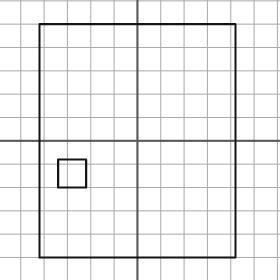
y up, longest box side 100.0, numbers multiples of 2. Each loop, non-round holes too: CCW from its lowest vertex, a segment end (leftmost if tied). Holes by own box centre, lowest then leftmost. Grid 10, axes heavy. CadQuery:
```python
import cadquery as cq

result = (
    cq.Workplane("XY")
    .moveTo(-42.0, -50.0)
    .lineTo(42.0, -50.0)
    .lineTo(42.0, 50.0)
    .lineTo(-42.0, 50.0)
    .close()
    .moveTo(-34.0, -20.0)
    .lineTo(-22.0, -20.0)
    .lineTo(-22.0, -8.0)
    .lineTo(-34.0, -8.0)
    .close()
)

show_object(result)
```